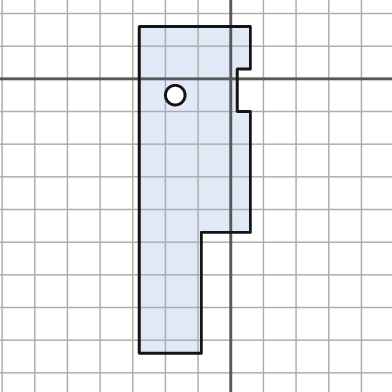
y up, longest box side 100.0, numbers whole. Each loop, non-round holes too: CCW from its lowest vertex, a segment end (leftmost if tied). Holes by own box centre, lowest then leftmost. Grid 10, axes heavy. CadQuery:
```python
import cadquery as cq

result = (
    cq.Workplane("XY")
    .moveTo(-28.0, -84.0)
    .lineTo(-9.0, -84.0)
    .lineTo(-9.0, -47.0)
    .lineTo(6.0, -47.0)
    .lineTo(6.0, -10.0)
    .lineTo(2.0, -10.0)
    .lineTo(2.0, 3.0)
    .lineTo(6.0, 3.0)
    .lineTo(6.0, 16.0)
    .lineTo(-28.0, 16.0)
    .close()
    .moveTo(-17.0, -5.0)
    .circle(3.0)
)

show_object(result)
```